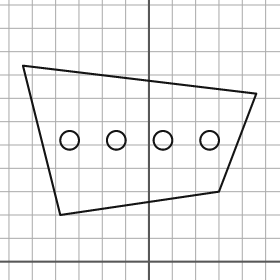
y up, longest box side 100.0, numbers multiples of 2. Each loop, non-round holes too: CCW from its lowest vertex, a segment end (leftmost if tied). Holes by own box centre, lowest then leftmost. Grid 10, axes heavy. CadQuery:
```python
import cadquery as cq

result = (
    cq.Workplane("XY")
    .moveTo(-38.0, 20.0)
    .lineTo(30.0, 30.0)
    .lineTo(46.0, 72.0)
    .lineTo(-54.0, 84.0)
    .close()
    .moveTo(-34.0, 52.0)
    .circle(4.0)
    .moveTo(-14.0, 52.0)
    .circle(4.0)
    .moveTo(6.0, 52.0)
    .circle(4.0)
    .moveTo(26.0, 52.0)
    .circle(4.0)
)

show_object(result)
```